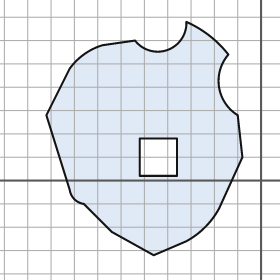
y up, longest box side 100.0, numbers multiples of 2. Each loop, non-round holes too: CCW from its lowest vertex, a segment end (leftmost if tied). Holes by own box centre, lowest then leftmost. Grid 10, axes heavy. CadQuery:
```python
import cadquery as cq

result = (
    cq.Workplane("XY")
    .moveTo(-46.0, -32.0)
    .lineTo(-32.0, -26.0)
    .threePointArc((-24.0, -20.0), (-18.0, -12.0))
    .lineTo(-8.0, 10.0)
    .lineTo(-10.0, 28.0)
    .threePointArc((-18.0, 40.0), (-14.0, 54.0))
    .threePointArc((-22.0, 62.0), (-32.0, 68.0))
    .threePointArc((-40.0, 56.0), (-54.0, 60.0))
    .lineTo(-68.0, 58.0)
    .threePointArc((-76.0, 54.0), (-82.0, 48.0))
    .lineTo(-92.0, 28.0)
    .lineTo(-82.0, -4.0)
    .threePointArc((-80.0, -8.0), (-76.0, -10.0))
    .lineTo(-64.0, -22.0)
    .close()
    .moveTo(-52.0, 2.0)
    .lineTo(-36.0, 2.0)
    .lineTo(-36.0, 18.0)
    .lineTo(-52.0, 18.0)
    .close()
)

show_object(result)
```